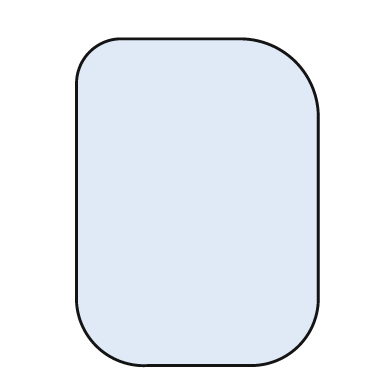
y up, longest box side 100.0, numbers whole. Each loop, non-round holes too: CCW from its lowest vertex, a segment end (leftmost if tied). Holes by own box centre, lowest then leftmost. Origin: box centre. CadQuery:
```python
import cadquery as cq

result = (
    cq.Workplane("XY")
    .moveTo(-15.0, -50.0)
    .lineTo(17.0, -50.0)
    .threePointArc((31.0, -44.0), (37.0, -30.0))
    .lineTo(37.0, 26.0)
    .threePointArc((30.0, 43.0), (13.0, 50.0))
    .lineTo(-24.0, 50.0)
    .threePointArc((-33.0, 46.0), (-37.0, 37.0))
    .lineTo(-37.0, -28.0)
    .threePointArc((-31.0, -44.0), (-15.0, -50.0))
    .close()
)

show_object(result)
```